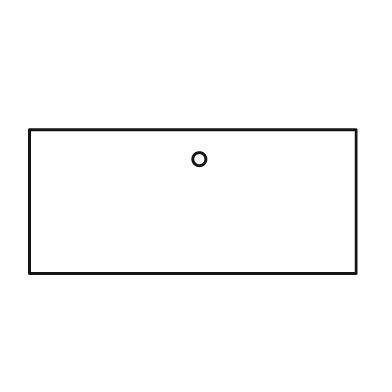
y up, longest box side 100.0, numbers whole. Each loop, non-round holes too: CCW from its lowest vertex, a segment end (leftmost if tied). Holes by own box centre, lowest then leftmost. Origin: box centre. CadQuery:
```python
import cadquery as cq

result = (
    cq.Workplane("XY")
    .moveTo(-50.0, -22.0)
    .lineTo(50.0, -22.0)
    .lineTo(50.0, 22.0)
    .lineTo(-50.0, 22.0)
    .close()
    .moveTo(2.0, 13.0)
    .circle(2.0)
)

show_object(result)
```